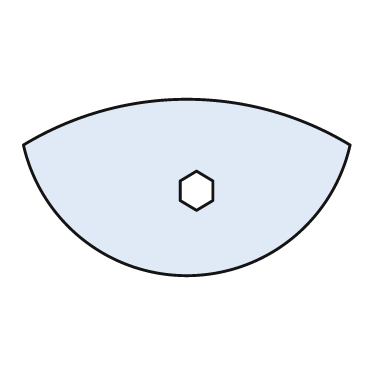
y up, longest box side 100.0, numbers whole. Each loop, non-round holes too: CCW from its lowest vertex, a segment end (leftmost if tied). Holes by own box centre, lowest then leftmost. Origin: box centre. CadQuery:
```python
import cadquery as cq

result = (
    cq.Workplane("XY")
    .moveTo(-50.0, 13.0)
    .threePointArc((0.0, -27.0), (50.0, 13.0))
    .threePointArc((0.0, 27.0), (-50.0, 13.0))
    .close()
    .moveTo(3.0, -7.0)
    .lineTo(8.0, -4.0)
    .lineTo(8.0, 2.0)
    .lineTo(3.0, 5.0)
    .lineTo(-2.0, 2.0)
    .lineTo(-2.0, -4.0)
    .close()
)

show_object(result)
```